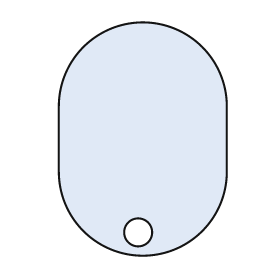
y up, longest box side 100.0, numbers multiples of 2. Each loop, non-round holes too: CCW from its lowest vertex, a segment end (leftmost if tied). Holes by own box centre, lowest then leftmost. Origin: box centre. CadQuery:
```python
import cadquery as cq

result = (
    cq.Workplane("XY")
    .moveTo(-36.0, -14.0)
    .threePointArc((0.0, -50.0), (36.0, -14.0))
    .lineTo(36.0, 14.0)
    .threePointArc((0.0, 50.0), (-36.0, 14.0))
    .close()
    .moveTo(-2.0, -40.0)
    .circle(6.0)
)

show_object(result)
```